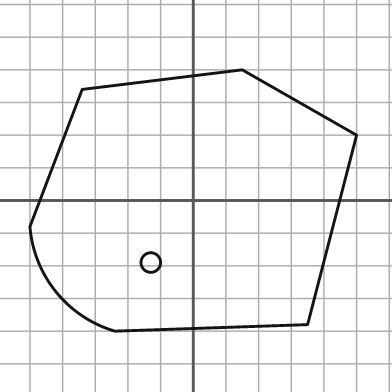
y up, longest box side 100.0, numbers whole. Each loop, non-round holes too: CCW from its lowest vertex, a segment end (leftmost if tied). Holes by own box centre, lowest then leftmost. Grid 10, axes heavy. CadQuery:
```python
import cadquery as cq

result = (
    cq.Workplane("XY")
    .moveTo(-24.0, -40.0)
    .lineTo(35.0, -38.0)
    .lineTo(50.0, 20.0)
    .lineTo(15.0, 40.0)
    .lineTo(-34.0, 34.0)
    .lineTo(-50.0, -8.0)
    .threePointArc((-42.0, -28.0), (-24.0, -40.0))
    .close()
    .moveTo(-13.0, -19.0)
    .circle(3.0)
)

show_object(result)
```